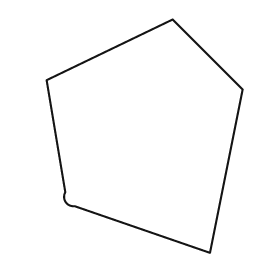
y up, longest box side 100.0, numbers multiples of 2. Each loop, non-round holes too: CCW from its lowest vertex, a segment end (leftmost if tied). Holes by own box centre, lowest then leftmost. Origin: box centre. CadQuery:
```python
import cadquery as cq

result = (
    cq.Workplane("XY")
    .moveTo(28.0, -50.0)
    .lineTo(42.0, 20.0)
    .lineTo(12.0, 50.0)
    .lineTo(-42.0, 24.0)
    .lineTo(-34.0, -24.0)
    .threePointArc((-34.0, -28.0), (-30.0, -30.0))
    .close()
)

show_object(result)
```